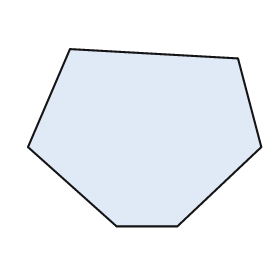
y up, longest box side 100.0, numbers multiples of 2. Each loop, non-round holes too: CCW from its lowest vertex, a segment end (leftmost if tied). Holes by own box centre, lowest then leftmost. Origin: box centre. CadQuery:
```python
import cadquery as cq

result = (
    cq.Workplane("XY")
    .moveTo(-12.0, -38.0)
    .lineTo(14.0, -38.0)
    .lineTo(50.0, -4.0)
    .lineTo(40.0, 34.0)
    .lineTo(-32.0, 38.0)
    .lineTo(-50.0, -4.0)
    .close()
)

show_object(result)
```